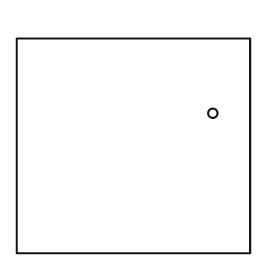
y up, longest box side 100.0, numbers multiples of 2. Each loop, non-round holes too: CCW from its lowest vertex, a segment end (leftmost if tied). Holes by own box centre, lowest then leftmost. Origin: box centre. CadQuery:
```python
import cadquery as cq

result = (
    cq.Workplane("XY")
    .moveTo(-50.0, -46.0)
    .lineTo(50.0, -46.0)
    .lineTo(50.0, 46.0)
    .lineTo(-50.0, 46.0)
    .close()
    .moveTo(34.0, 14.0)
    .circle(2.0)
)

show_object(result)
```